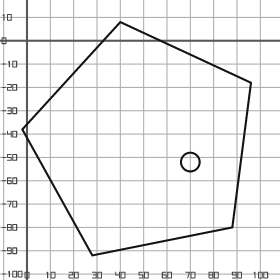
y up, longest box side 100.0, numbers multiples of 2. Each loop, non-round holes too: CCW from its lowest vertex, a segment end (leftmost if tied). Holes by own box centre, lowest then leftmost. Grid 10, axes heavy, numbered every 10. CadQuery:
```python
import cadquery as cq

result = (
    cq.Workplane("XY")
    .moveTo(28.0, -92.0)
    .lineTo(88.0, -80.0)
    .lineTo(96.0, -18.0)
    .lineTo(40.0, 8.0)
    .lineTo(-2.0, -38.0)
    .close()
    .moveTo(70.0, -52.0)
    .circle(4.0)
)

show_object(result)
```